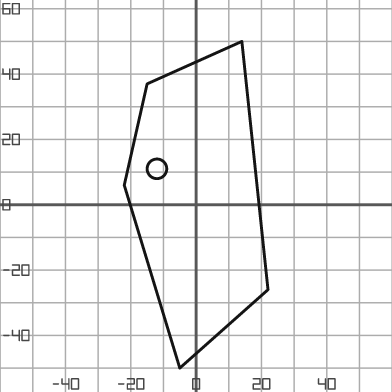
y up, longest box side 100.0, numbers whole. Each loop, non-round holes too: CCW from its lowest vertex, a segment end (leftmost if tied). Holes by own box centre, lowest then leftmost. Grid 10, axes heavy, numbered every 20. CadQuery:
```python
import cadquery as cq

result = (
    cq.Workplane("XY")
    .moveTo(-5.0, -50.0)
    .lineTo(22.0, -26.0)
    .lineTo(14.0, 50.0)
    .lineTo(-15.0, 37.0)
    .lineTo(-22.0, 6.0)
    .close()
    .moveTo(-12.0, 11.0)
    .circle(3.0)
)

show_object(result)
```